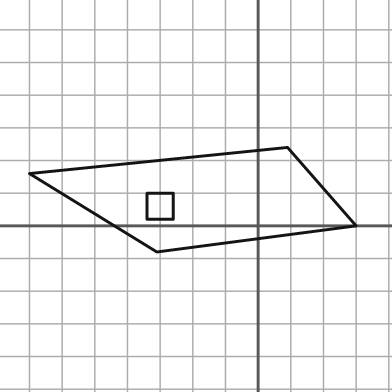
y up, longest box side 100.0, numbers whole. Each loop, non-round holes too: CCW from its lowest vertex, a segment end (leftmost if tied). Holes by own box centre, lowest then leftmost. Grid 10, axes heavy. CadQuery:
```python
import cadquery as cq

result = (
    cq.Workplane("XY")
    .moveTo(-31.0, -8.0)
    .lineTo(30.0, 0.0)
    .lineTo(9.0, 24.0)
    .lineTo(-70.0, 16.0)
    .close()
    .moveTo(-34.0, 2.0)
    .lineTo(-26.0, 2.0)
    .lineTo(-26.0, 10.0)
    .lineTo(-34.0, 10.0)
    .close()
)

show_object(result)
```